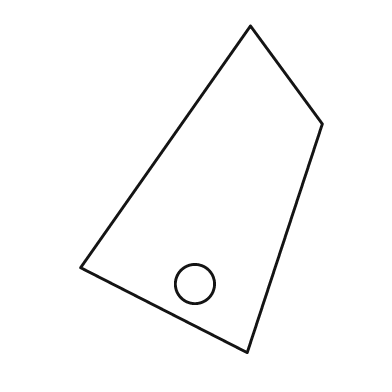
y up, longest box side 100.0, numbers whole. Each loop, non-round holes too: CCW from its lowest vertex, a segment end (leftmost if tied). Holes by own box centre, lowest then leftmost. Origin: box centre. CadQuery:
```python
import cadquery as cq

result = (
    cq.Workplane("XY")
    .moveTo(14.0, -50.0)
    .lineTo(37.0, 20.0)
    .lineTo(15.0, 50.0)
    .lineTo(-37.0, -24.0)
    .close()
    .moveTo(-2.0, -29.0)
    .circle(6.0)
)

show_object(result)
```